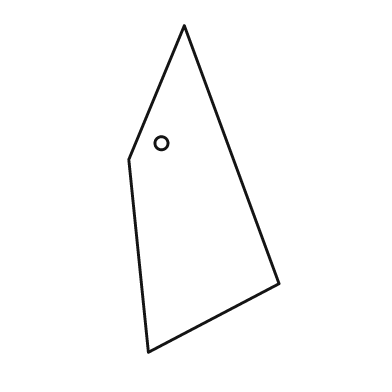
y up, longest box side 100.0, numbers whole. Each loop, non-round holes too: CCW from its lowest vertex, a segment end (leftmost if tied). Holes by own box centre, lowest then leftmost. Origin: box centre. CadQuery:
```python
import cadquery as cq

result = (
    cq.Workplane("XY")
    .moveTo(-17.0, -50.0)
    .lineTo(23.0, -29.0)
    .lineTo(-6.0, 50.0)
    .lineTo(-23.0, 9.0)
    .close()
    .moveTo(-13.0, 14.0)
    .circle(2.0)
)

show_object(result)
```